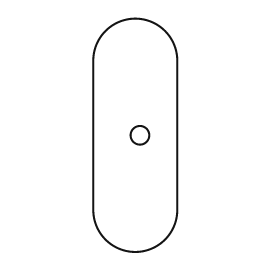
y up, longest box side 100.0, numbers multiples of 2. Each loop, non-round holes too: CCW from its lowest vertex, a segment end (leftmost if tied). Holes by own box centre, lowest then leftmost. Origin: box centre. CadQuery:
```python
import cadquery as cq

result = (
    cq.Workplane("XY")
    .moveTo(-18.0, -32.0)
    .threePointArc((0.0, -50.0), (18.0, -32.0))
    .lineTo(18.0, 32.0)
    .threePointArc((0.0, 50.0), (-18.0, 32.0))
    .close()
    .moveTo(2.0, 0.0)
    .circle(4.0)
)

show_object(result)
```